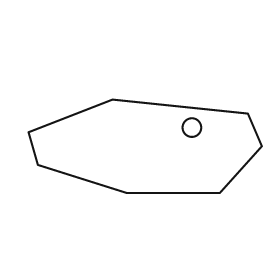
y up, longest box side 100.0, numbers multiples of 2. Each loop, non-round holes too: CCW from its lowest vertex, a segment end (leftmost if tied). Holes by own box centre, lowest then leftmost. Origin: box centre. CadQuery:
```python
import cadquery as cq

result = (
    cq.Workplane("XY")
    .moveTo(-8.0, -20.0)
    .lineTo(32.0, -20.0)
    .lineTo(50.0, 0.0)
    .lineTo(44.0, 14.0)
    .lineTo(-14.0, 20.0)
    .lineTo(-50.0, 6.0)
    .lineTo(-46.0, -8.0)
    .close()
    .moveTo(20.0, 8.0)
    .circle(4.0)
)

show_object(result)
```